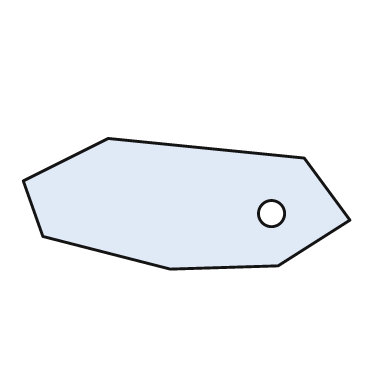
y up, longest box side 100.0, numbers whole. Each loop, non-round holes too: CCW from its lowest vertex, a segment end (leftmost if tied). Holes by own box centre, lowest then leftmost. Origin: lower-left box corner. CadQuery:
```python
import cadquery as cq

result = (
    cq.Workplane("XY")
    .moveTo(45.0, 0.0)
    .lineTo(78.0, 1.0)
    .lineTo(100.0, 15.0)
    .lineTo(86.0, 34.0)
    .lineTo(26.0, 40.0)
    .lineTo(0.0, 27.0)
    .lineTo(6.0, 10.0)
    .close()
    .moveTo(76.0, 17.0)
    .circle(4.0)
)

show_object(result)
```